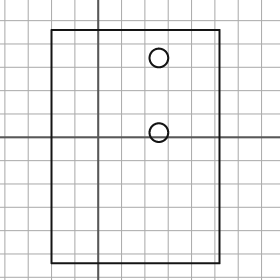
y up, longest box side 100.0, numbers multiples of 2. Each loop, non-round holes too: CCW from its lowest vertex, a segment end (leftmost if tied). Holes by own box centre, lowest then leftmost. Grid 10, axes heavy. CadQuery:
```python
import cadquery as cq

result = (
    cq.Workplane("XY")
    .moveTo(-20.0, -54.0)
    .lineTo(52.0, -54.0)
    .lineTo(52.0, 46.0)
    .lineTo(-20.0, 46.0)
    .close()
    .moveTo(26.0, 2.0)
    .circle(4.0)
    .moveTo(26.0, 34.0)
    .circle(4.0)
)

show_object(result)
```